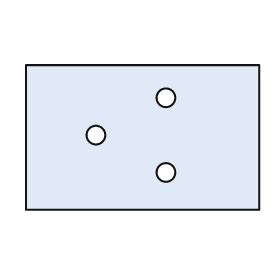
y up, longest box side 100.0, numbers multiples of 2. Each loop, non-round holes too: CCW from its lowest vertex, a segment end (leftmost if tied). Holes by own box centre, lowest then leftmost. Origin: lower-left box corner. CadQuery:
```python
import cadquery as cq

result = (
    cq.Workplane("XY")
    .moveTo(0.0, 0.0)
    .lineTo(100.0, 0.0)
    .lineTo(100.0, 62.0)
    .lineTo(0.0, 62.0)
    .close()
    .moveTo(60.0, 16.0)
    .circle(4.0)
    .moveTo(30.0, 32.0)
    .circle(4.0)
    .moveTo(60.0, 48.0)
    .circle(4.0)
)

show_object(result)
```